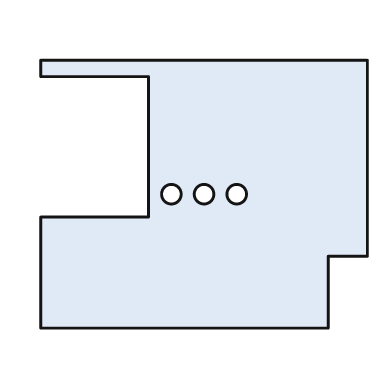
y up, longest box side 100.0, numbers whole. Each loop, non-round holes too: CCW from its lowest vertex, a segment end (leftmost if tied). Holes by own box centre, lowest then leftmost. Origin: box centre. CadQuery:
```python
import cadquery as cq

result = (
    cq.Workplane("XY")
    .moveTo(-50.0, -41.0)
    .lineTo(38.0, -41.0)
    .lineTo(38.0, -19.0)
    .lineTo(50.0, -19.0)
    .lineTo(50.0, 41.0)
    .lineTo(-50.0, 41.0)
    .lineTo(-50.0, 36.0)
    .lineTo(-17.0, 36.0)
    .lineTo(-17.0, -7.0)
    .lineTo(-50.0, -7.0)
    .close()
    .moveTo(-10.0, 0.0)
    .circle(3.0)
    .moveTo(0.0, 0.0)
    .circle(3.0)
    .moveTo(10.0, 0.0)
    .circle(3.0)
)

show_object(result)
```